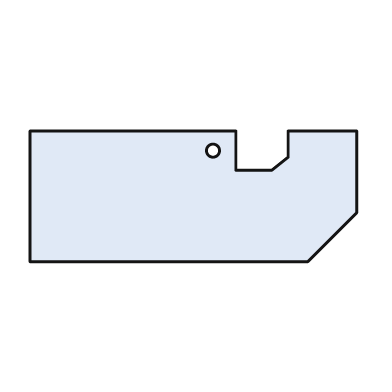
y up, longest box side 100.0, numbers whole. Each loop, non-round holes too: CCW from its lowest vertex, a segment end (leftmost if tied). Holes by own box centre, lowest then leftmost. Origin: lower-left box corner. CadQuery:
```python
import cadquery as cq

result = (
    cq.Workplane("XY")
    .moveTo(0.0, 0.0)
    .lineTo(85.0, 0.0)
    .lineTo(100.0, 15.0)
    .lineTo(100.0, 40.0)
    .lineTo(79.0, 40.0)
    .lineTo(79.0, 32.0)
    .lineTo(74.0, 28.0)
    .lineTo(63.0, 28.0)
    .lineTo(63.0, 40.0)
    .lineTo(0.0, 40.0)
    .close()
    .moveTo(56.0, 34.0)
    .circle(2.0)
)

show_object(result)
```